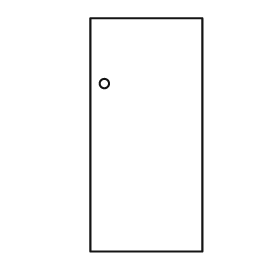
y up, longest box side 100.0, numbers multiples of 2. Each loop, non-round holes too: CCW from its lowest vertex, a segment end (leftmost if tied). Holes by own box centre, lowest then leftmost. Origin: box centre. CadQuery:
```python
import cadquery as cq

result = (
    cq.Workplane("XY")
    .moveTo(-24.0, -50.0)
    .lineTo(24.0, -50.0)
    .lineTo(24.0, 50.0)
    .lineTo(-24.0, 50.0)
    .close()
    .moveTo(-18.0, 22.0)
    .circle(2.0)
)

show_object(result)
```